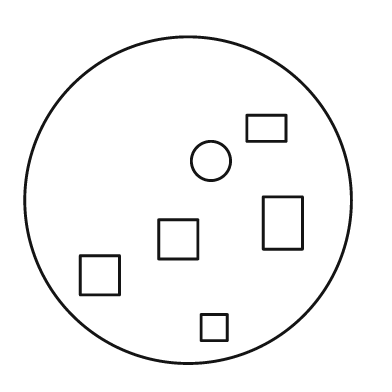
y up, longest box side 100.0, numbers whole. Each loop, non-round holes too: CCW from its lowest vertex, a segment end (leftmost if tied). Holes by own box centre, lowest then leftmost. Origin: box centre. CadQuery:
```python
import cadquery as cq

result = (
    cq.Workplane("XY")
    .moveTo(0.0, 0.0)
    .circle(50.0)
    .moveTo(4.0, -43.0)
    .lineTo(12.0, -43.0)
    .lineTo(12.0, -35.0)
    .lineTo(4.0, -35.0)
    .close()
    .moveTo(-33.0, -29.0)
    .lineTo(-21.0, -29.0)
    .lineTo(-21.0, -17.0)
    .lineTo(-33.0, -17.0)
    .close()
    .moveTo(-9.0, -18.0)
    .lineTo(3.0, -18.0)
    .lineTo(3.0, -6.0)
    .lineTo(-9.0, -6.0)
    .close()
    .moveTo(23.0, -15.0)
    .lineTo(35.0, -15.0)
    .lineTo(35.0, 1.0)
    .lineTo(23.0, 1.0)
    .close()
    .moveTo(7.0, 12.0)
    .circle(6.0)
    .moveTo(18.0, 18.0)
    .lineTo(30.0, 18.0)
    .lineTo(30.0, 26.0)
    .lineTo(18.0, 26.0)
    .close()
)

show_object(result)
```